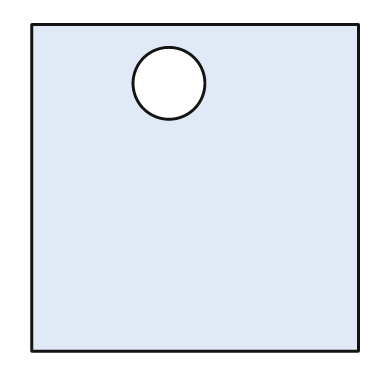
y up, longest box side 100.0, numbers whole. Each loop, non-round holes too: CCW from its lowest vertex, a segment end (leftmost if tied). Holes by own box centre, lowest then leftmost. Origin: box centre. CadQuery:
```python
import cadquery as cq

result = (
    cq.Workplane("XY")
    .moveTo(-50.0, -50.0)
    .lineTo(50.0, -50.0)
    .lineTo(50.0, 50.0)
    .lineTo(-50.0, 50.0)
    .close()
    .moveTo(-8.0, 32.0)
    .circle(11.0)
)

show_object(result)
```